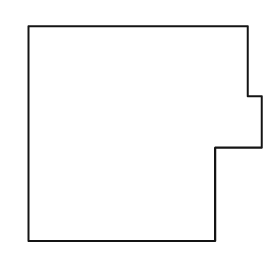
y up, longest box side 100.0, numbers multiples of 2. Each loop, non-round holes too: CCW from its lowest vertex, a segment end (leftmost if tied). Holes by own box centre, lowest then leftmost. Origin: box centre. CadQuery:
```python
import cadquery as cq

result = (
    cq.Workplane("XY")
    .moveTo(-50.0, -46.0)
    .lineTo(30.0, -46.0)
    .lineTo(30.0, -6.0)
    .lineTo(50.0, -6.0)
    .lineTo(50.0, 16.0)
    .lineTo(44.0, 16.0)
    .lineTo(44.0, 46.0)
    .lineTo(-50.0, 46.0)
    .close()
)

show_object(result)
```